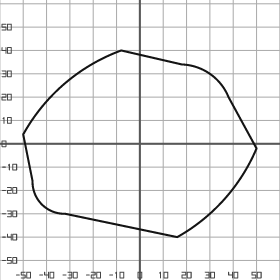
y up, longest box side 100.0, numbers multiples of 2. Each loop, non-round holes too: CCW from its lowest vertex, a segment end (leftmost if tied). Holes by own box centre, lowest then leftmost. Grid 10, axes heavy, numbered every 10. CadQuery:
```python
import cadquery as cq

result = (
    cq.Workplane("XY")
    .moveTo(16.0, -40.0)
    .threePointArc((36.0, -24.0), (50.0, -2.0))
    .lineTo(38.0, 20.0)
    .threePointArc((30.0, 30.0), (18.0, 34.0))
    .lineTo(-8.0, 40.0)
    .threePointArc((-32.0, 26.0), (-50.0, 4.0))
    .lineTo(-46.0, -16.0)
    .threePointArc((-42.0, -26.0), (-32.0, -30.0))
    .close()
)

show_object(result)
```